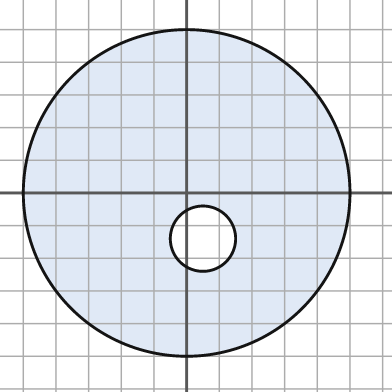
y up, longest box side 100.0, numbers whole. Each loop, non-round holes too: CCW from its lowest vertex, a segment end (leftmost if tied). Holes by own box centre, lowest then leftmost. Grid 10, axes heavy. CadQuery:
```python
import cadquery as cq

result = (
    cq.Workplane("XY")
    .moveTo(0.0, 0.0)
    .circle(50.0)
    .moveTo(5.0, -14.0)
    .circle(10.0)
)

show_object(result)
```